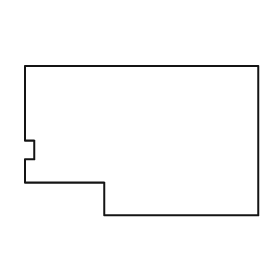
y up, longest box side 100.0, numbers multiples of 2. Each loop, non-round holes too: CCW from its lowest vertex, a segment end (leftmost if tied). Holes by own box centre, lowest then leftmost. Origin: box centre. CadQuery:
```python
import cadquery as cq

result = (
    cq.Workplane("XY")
    .moveTo(-16.0, -32.0)
    .lineTo(50.0, -32.0)
    .lineTo(50.0, 32.0)
    .lineTo(-50.0, 32.0)
    .lineTo(-50.0, 0.0)
    .lineTo(-46.0, 0.0)
    .lineTo(-46.0, -8.0)
    .lineTo(-50.0, -8.0)
    .lineTo(-50.0, -18.0)
    .lineTo(-16.0, -18.0)
    .close()
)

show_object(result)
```